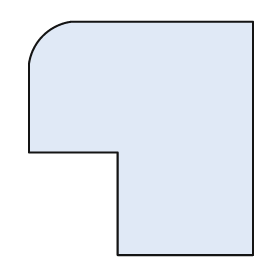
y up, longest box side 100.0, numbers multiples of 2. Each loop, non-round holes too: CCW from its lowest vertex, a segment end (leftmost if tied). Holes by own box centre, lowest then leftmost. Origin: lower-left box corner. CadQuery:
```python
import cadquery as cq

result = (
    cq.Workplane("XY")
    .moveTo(38.0, 0.0)
    .lineTo(96.0, 0.0)
    .lineTo(96.0, 100.0)
    .lineTo(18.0, 100.0)
    .threePointArc((6.0, 94.0), (0.0, 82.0))
    .lineTo(0.0, 44.0)
    .lineTo(38.0, 44.0)
    .close()
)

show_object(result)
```